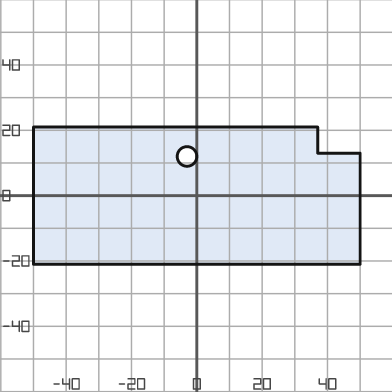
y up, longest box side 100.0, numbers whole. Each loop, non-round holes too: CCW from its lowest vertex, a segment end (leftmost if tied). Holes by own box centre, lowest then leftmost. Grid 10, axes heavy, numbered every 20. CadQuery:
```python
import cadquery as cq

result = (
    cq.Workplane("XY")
    .moveTo(-50.0, -21.0)
    .lineTo(50.0, -21.0)
    .lineTo(50.0, 13.0)
    .lineTo(37.0, 13.0)
    .lineTo(37.0, 21.0)
    .lineTo(-50.0, 21.0)
    .close()
    .moveTo(-3.0, 12.0)
    .circle(3.0)
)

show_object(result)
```